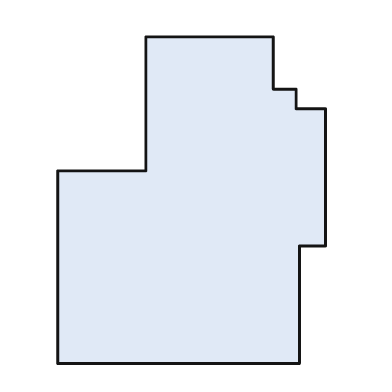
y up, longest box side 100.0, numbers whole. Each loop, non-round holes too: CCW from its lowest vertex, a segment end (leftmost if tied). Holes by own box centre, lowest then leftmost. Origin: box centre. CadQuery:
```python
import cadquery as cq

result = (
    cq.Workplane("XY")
    .moveTo(-41.0, -50.0)
    .lineTo(33.0, -50.0)
    .lineTo(33.0, -14.0)
    .lineTo(41.0, -14.0)
    .lineTo(41.0, 28.0)
    .lineTo(32.0, 28.0)
    .lineTo(32.0, 34.0)
    .lineTo(25.0, 34.0)
    .lineTo(25.0, 50.0)
    .lineTo(-14.0, 50.0)
    .lineTo(-14.0, 9.0)
    .lineTo(-41.0, 9.0)
    .close()
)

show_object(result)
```